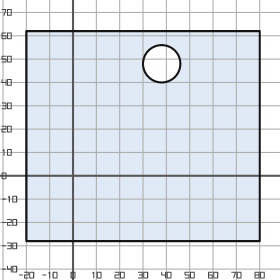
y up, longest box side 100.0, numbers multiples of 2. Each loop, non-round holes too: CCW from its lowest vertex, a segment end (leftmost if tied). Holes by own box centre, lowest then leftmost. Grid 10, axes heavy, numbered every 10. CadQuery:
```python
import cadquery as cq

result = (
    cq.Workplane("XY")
    .moveTo(-20.0, -28.0)
    .lineTo(80.0, -28.0)
    .lineTo(80.0, 62.0)
    .lineTo(-20.0, 62.0)
    .close()
    .moveTo(38.0, 48.0)
    .circle(8.0)
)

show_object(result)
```